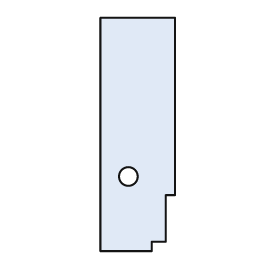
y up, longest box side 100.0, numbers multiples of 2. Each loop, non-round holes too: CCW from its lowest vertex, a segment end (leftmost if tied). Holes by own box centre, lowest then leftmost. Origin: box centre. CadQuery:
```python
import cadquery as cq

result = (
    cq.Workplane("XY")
    .moveTo(-16.0, -50.0)
    .lineTo(6.0, -50.0)
    .lineTo(6.0, -46.0)
    .lineTo(12.0, -46.0)
    .lineTo(12.0, -26.0)
    .lineTo(16.0, -26.0)
    .lineTo(16.0, 50.0)
    .lineTo(-16.0, 50.0)
    .close()
    .moveTo(-4.0, -18.0)
    .circle(4.0)
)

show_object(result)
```